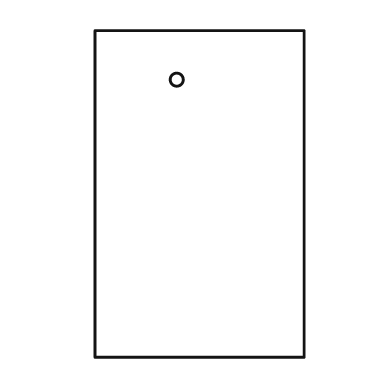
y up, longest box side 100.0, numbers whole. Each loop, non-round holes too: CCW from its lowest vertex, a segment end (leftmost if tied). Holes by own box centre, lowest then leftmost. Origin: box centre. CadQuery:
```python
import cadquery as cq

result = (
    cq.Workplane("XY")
    .moveTo(-32.0, -50.0)
    .lineTo(32.0, -50.0)
    .lineTo(32.0, 50.0)
    .lineTo(-32.0, 50.0)
    .close()
    .moveTo(-7.0, 35.0)
    .circle(2.0)
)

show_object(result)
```